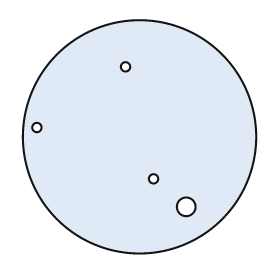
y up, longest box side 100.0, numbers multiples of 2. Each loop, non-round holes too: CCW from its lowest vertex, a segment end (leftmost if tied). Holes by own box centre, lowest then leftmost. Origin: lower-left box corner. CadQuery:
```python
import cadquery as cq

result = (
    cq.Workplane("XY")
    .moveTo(50.0, 50.0)
    .circle(50.0)
    .moveTo(70.0, 20.0)
    .circle(4.0)
    .moveTo(56.0, 32.0)
    .circle(2.0)
    .moveTo(6.0, 54.0)
    .circle(2.0)
    .moveTo(44.0, 80.0)
    .circle(2.0)
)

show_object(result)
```